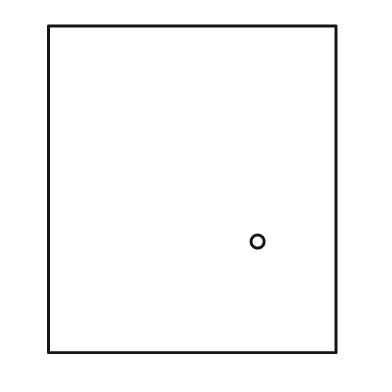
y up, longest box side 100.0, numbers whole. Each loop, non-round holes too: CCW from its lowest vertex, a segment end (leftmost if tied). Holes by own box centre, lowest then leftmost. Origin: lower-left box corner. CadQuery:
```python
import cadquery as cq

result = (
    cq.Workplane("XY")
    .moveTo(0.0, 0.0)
    .lineTo(88.0, 0.0)
    .lineTo(88.0, 100.0)
    .lineTo(0.0, 100.0)
    .close()
    .moveTo(64.0, 34.0)
    .circle(2.0)
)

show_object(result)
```